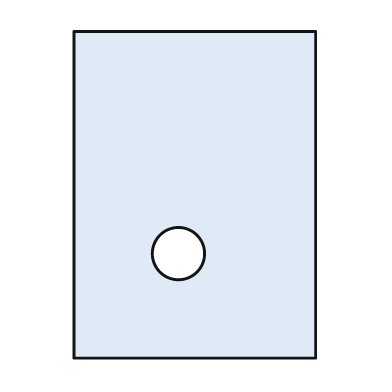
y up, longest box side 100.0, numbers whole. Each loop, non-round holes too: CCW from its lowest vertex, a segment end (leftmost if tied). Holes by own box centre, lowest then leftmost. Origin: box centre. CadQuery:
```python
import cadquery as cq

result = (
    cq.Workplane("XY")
    .moveTo(-37.0, -50.0)
    .lineTo(37.0, -50.0)
    .lineTo(37.0, 50.0)
    .lineTo(-37.0, 50.0)
    .close()
    .moveTo(-5.0, -18.0)
    .circle(8.0)
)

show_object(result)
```